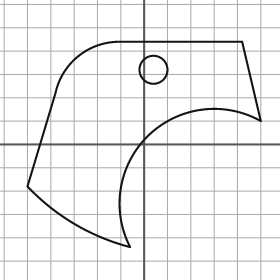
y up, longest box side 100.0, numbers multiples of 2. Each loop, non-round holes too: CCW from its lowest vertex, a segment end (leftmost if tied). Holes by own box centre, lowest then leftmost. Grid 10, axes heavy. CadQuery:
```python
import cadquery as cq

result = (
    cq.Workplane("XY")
    .moveTo(-6.0, -44.0)
    .threePointArc((2.0, 4.0), (50.0, 10.0))
    .lineTo(42.0, 44.0)
    .lineTo(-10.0, 44.0)
    .threePointArc((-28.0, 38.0), (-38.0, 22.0))
    .lineTo(-50.0, -18.0)
    .threePointArc((-30.0, -34.0), (-6.0, -44.0))
    .close()
    .moveTo(4.0, 32.0)
    .circle(6.0)
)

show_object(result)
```